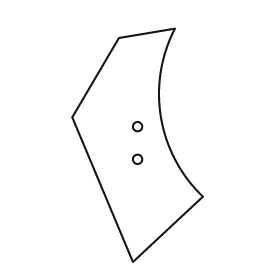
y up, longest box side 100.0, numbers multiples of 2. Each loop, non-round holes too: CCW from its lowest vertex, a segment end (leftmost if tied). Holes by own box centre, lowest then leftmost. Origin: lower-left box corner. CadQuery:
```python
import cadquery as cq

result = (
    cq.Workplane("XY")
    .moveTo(26.0, 0.0)
    .lineTo(56.0, 28.0)
    .threePointArc((38.0, 62.0), (44.0, 100.0))
    .lineTo(20.0, 96.0)
    .lineTo(0.0, 62.0)
    .close()
    .moveTo(28.0, 44.0)
    .circle(2.0)
    .moveTo(28.0, 58.0)
    .circle(2.0)
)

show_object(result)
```